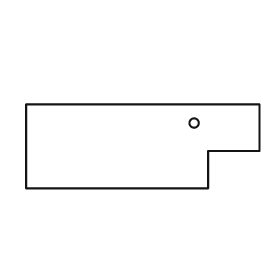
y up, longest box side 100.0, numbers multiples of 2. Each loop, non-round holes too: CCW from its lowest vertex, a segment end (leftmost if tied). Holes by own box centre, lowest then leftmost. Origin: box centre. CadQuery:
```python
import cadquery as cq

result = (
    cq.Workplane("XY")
    .moveTo(-50.0, -18.0)
    .lineTo(28.0, -18.0)
    .lineTo(28.0, -2.0)
    .lineTo(50.0, -2.0)
    .lineTo(50.0, 18.0)
    .lineTo(-50.0, 18.0)
    .close()
    .moveTo(22.0, 10.0)
    .circle(2.0)
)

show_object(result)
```